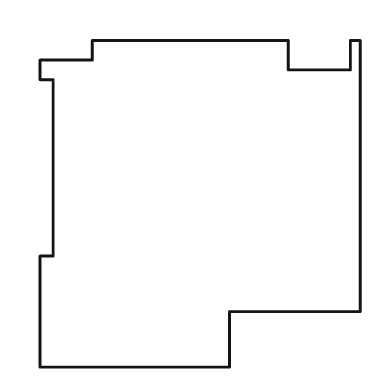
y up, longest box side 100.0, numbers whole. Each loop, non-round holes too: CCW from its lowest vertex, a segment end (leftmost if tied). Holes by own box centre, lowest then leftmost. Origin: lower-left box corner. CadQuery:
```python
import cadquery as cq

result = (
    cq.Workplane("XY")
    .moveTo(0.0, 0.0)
    .lineTo(58.0, 0.0)
    .lineTo(58.0, 17.0)
    .lineTo(98.0, 17.0)
    .lineTo(98.0, 100.0)
    .lineTo(95.0, 100.0)
    .lineTo(95.0, 91.0)
    .lineTo(76.0, 91.0)
    .lineTo(76.0, 100.0)
    .lineTo(16.0, 100.0)
    .lineTo(16.0, 94.0)
    .lineTo(0.0, 94.0)
    .lineTo(0.0, 88.0)
    .lineTo(4.0, 88.0)
    .lineTo(4.0, 34.0)
    .lineTo(0.0, 34.0)
    .close()
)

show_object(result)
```